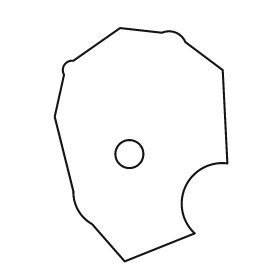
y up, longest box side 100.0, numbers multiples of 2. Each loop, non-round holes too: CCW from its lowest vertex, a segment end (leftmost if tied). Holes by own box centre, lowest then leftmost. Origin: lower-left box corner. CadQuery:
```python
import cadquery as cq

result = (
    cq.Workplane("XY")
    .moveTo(30.0, 0.0)
    .lineTo(60.0, 12.0)
    .threePointArc((56.0, 32.0), (74.0, 42.0))
    .lineTo(72.0, 82.0)
    .lineTo(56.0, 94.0)
    .threePointArc((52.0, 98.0), (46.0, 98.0))
    .lineTo(28.0, 100.0)
    .lineTo(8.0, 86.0)
    .threePointArc((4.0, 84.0), (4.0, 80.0))
    .lineTo(0.0, 62.0)
    .lineTo(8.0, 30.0)
    .threePointArc((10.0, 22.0), (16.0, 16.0))
    .close()
    .moveTo(32.0, 46.0)
    .circle(6.0)
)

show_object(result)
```